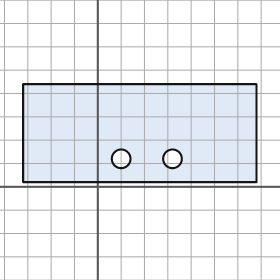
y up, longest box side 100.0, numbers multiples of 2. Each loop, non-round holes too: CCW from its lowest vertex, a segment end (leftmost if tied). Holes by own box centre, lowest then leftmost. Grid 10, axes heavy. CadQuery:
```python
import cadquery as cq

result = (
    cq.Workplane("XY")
    .moveTo(-32.0, 2.0)
    .lineTo(68.0, 2.0)
    .lineTo(68.0, 44.0)
    .lineTo(-32.0, 44.0)
    .close()
    .moveTo(10.0, 12.0)
    .circle(4.0)
    .moveTo(32.0, 12.0)
    .circle(4.0)
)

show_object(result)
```